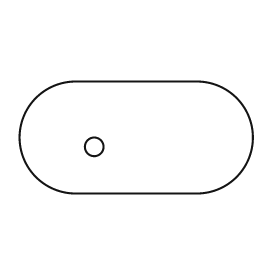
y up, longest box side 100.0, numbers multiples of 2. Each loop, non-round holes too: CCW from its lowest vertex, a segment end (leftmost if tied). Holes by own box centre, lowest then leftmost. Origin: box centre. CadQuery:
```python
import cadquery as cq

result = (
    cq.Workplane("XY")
    .moveTo(-26.0, -24.0)
    .lineTo(26.0, -24.0)
    .threePointArc((50.0, 0.0), (26.0, 24.0))
    .lineTo(-26.0, 24.0)
    .threePointArc((-50.0, 0.0), (-26.0, -24.0))
    .close()
    .moveTo(-18.0, -4.0)
    .circle(4.0)
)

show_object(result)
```